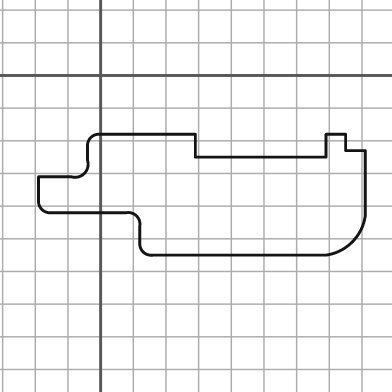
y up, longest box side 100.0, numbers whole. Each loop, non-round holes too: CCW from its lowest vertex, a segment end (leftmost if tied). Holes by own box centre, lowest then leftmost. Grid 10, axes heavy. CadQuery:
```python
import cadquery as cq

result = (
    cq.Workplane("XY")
    .moveTo(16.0, -55.0)
    .lineTo(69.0, -55.0)
    .threePointArc((77.0, -51.0), (81.0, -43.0))
    .lineTo(81.0, -23.0)
    .lineTo(75.0, -23.0)
    .lineTo(75.0, -18.0)
    .lineTo(69.0, -18.0)
    .lineTo(69.0, -25.0)
    .lineTo(29.0, -25.0)
    .lineTo(29.0, -18.0)
    .lineTo(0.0, -18.0)
    .threePointArc((-3.0, -19.0), (-4.0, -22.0))
    .lineTo(-4.0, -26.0)
    .threePointArc((-5.0, -30.0), (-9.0, -31.0))
    .lineTo(-19.0, -31.0)
    .lineTo(-19.0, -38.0)
    .threePointArc((-18.0, -41.0), (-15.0, -42.0))
    .lineTo(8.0, -42.0)
    .threePointArc((11.0, -43.0), (12.0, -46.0))
    .lineTo(12.0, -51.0)
    .threePointArc((13.0, -54.0), (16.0, -55.0))
    .close()
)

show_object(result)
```